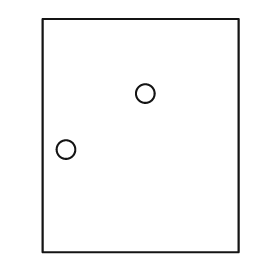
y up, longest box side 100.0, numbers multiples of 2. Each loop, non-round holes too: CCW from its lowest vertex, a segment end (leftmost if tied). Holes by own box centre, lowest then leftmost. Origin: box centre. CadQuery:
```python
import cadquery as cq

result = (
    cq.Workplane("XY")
    .moveTo(-42.0, -50.0)
    .lineTo(42.0, -50.0)
    .lineTo(42.0, 50.0)
    .lineTo(-42.0, 50.0)
    .close()
    .moveTo(-32.0, -6.0)
    .circle(4.0)
    .moveTo(2.0, 18.0)
    .circle(4.0)
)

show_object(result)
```